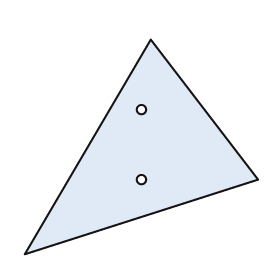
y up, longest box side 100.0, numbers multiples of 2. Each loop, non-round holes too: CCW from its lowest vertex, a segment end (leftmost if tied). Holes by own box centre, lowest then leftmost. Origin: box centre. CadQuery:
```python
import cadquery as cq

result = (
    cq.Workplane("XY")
    .moveTo(-50.0, -46.0)
    .lineTo(50.0, -14.0)
    .lineTo(4.0, 46.0)
    .close()
    .moveTo(0.0, -14.0)
    .circle(2.0)
    .moveTo(0.0, 16.0)
    .circle(2.0)
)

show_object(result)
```